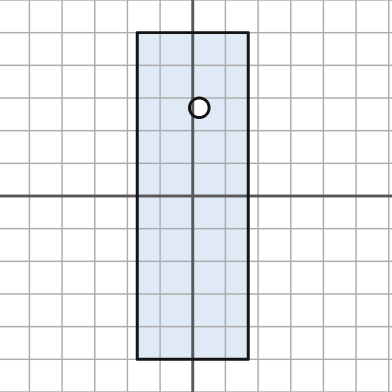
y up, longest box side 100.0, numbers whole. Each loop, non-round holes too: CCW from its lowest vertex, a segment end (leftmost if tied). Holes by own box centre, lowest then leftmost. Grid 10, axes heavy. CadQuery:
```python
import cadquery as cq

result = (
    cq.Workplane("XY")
    .moveTo(-17.0, -50.0)
    .lineTo(17.0, -50.0)
    .lineTo(17.0, 50.0)
    .lineTo(-17.0, 50.0)
    .close()
    .moveTo(2.0, 27.0)
    .circle(3.0)
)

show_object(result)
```